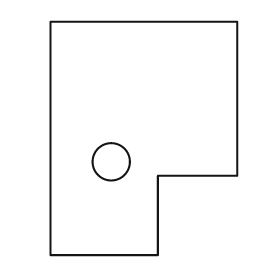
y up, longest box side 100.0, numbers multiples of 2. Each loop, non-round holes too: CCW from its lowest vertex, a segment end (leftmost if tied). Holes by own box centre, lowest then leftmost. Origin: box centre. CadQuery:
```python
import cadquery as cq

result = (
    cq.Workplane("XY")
    .moveTo(-40.0, -50.0)
    .lineTo(6.0, -50.0)
    .lineTo(6.0, -16.0)
    .lineTo(40.0, -16.0)
    .lineTo(40.0, 50.0)
    .lineTo(-40.0, 50.0)
    .close()
    .moveTo(-14.0, -10.0)
    .circle(8.0)
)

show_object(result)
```